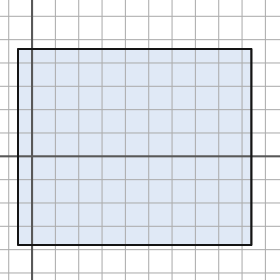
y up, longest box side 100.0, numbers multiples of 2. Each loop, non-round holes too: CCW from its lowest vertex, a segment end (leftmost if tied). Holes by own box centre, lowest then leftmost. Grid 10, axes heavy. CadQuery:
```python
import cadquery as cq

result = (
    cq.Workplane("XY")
    .moveTo(-6.0, -38.0)
    .lineTo(94.0, -38.0)
    .lineTo(94.0, 46.0)
    .lineTo(-6.0, 46.0)
    .close()
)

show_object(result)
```